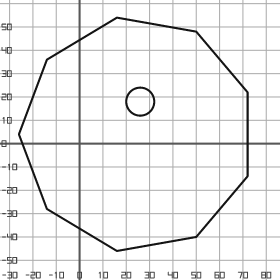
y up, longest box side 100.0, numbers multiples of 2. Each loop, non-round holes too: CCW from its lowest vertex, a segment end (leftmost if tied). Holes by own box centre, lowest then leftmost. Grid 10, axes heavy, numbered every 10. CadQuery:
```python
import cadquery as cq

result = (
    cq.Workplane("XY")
    .moveTo(16.0, -46.0)
    .lineTo(50.0, -40.0)
    .lineTo(72.0, -14.0)
    .lineTo(72.0, 22.0)
    .lineTo(50.0, 48.0)
    .lineTo(16.0, 54.0)
    .lineTo(-14.0, 36.0)
    .lineTo(-26.0, 4.0)
    .lineTo(-14.0, -28.0)
    .close()
    .moveTo(26.0, 18.0)
    .circle(6.0)
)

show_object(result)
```